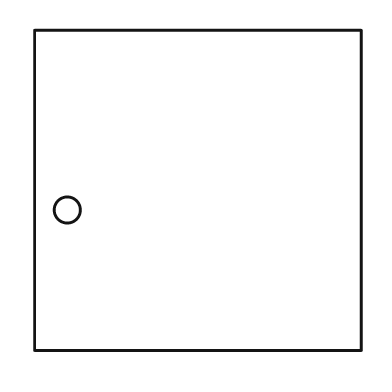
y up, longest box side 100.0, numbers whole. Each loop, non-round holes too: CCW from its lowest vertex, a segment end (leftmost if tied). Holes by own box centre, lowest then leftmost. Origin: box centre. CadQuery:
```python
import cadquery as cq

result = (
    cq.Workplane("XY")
    .moveTo(-50.0, -49.0)
    .lineTo(50.0, -49.0)
    .lineTo(50.0, 49.0)
    .lineTo(-50.0, 49.0)
    .close()
    .moveTo(-40.0, -6.0)
    .circle(4.0)
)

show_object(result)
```